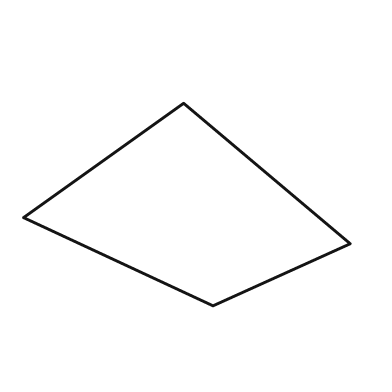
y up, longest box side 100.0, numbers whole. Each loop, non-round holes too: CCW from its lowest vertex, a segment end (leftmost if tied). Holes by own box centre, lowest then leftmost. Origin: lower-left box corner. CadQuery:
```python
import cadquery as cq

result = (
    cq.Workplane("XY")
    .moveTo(58.0, 0.0)
    .lineTo(100.0, 19.0)
    .lineTo(49.0, 62.0)
    .lineTo(0.0, 27.0)
    .close()
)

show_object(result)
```